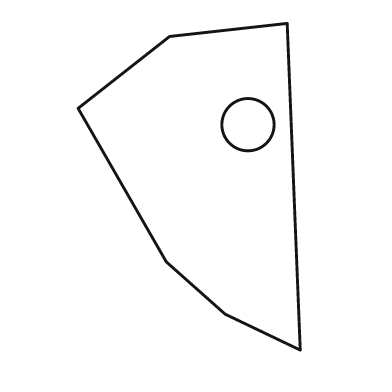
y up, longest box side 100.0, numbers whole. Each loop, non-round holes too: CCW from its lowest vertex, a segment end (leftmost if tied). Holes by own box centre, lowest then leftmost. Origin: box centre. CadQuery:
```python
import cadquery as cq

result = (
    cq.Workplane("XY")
    .moveTo(34.0, -50.0)
    .lineTo(30.0, 50.0)
    .lineTo(-6.0, 46.0)
    .lineTo(-34.0, 24.0)
    .lineTo(-7.0, -23.0)
    .lineTo(11.0, -39.0)
    .close()
    .moveTo(18.0, 19.0)
    .circle(8.0)
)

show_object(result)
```